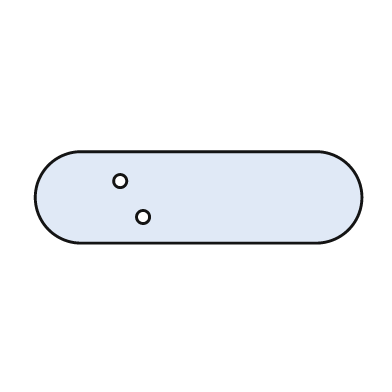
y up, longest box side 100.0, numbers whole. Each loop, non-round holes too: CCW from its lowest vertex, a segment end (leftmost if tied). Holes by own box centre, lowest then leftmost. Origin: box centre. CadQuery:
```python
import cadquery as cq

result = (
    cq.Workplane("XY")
    .moveTo(-36.0, -14.0)
    .lineTo(36.0, -14.0)
    .threePointArc((50.0, 0.0), (36.0, 14.0))
    .lineTo(-36.0, 14.0)
    .threePointArc((-50.0, 0.0), (-36.0, -14.0))
    .close()
    .moveTo(-17.0, -6.0)
    .circle(2.0)
    .moveTo(-24.0, 5.0)
    .circle(2.0)
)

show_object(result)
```